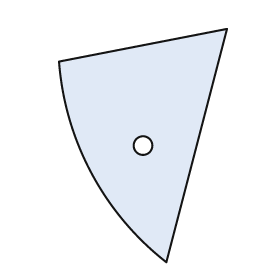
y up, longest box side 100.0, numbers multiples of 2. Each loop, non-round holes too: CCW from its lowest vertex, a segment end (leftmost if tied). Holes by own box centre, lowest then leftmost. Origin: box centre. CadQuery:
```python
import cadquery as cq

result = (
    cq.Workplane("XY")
    .moveTo(10.0, -50.0)
    .lineTo(36.0, 50.0)
    .lineTo(-36.0, 36.0)
    .threePointArc((-22.0, -12.0), (10.0, -50.0))
    .close()
    .moveTo(0.0, 0.0)
    .circle(4.0)
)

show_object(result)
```